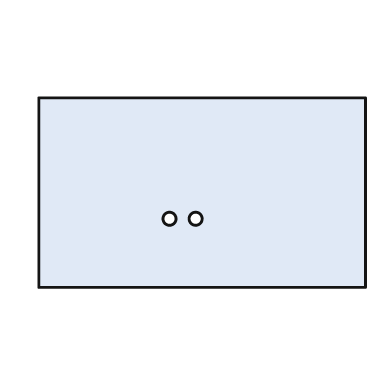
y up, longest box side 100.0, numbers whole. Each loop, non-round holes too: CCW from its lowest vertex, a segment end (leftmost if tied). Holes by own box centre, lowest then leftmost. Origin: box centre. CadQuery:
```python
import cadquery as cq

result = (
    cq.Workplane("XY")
    .moveTo(-50.0, -29.0)
    .lineTo(50.0, -29.0)
    .lineTo(50.0, 29.0)
    .lineTo(-50.0, 29.0)
    .close()
    .moveTo(-10.0, -8.0)
    .circle(2.0)
    .moveTo(-2.0, -8.0)
    .circle(2.0)
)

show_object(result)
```